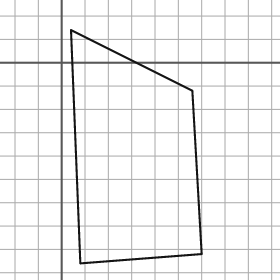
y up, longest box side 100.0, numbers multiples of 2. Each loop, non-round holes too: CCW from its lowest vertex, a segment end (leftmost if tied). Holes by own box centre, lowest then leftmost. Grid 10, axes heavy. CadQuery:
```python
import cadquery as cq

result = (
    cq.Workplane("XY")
    .moveTo(8.0, -86.0)
    .lineTo(60.0, -82.0)
    .lineTo(56.0, -12.0)
    .lineTo(4.0, 14.0)
    .close()
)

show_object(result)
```